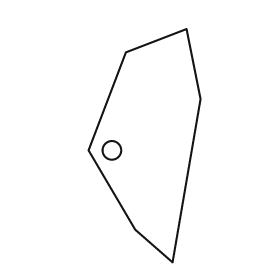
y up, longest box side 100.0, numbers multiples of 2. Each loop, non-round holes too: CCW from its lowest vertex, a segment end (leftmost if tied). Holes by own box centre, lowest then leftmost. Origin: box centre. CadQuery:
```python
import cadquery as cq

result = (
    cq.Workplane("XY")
    .moveTo(12.0, -50.0)
    .lineTo(24.0, 20.0)
    .lineTo(18.0, 50.0)
    .lineTo(-8.0, 40.0)
    .lineTo(-24.0, -2.0)
    .lineTo(-4.0, -36.0)
    .close()
    .moveTo(-14.0, -2.0)
    .circle(4.0)
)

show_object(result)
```